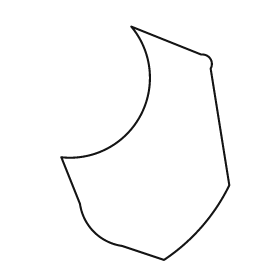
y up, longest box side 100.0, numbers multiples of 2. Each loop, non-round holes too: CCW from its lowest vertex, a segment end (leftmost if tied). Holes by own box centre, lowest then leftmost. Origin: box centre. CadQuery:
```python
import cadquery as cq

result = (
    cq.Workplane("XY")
    .moveTo(8.0, -50.0)
    .threePointArc((24.0, -36.0), (36.0, -18.0))
    .lineTo(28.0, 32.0)
    .threePointArc((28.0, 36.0), (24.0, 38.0))
    .lineTo(-6.0, 50.0)
    .threePointArc((-2.0, 12.0), (-36.0, -6.0))
    .lineTo(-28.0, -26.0)
    .threePointArc((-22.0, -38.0), (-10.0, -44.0))
    .close()
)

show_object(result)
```